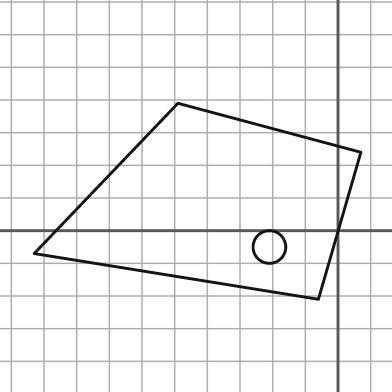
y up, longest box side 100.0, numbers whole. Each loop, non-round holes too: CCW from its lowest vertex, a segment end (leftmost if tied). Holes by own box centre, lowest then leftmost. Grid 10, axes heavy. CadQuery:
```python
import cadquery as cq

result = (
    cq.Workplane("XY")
    .moveTo(-6.0, -21.0)
    .lineTo(7.0, 24.0)
    .lineTo(-49.0, 39.0)
    .lineTo(-93.0, -7.0)
    .close()
    .moveTo(-21.0, -5.0)
    .circle(5.0)
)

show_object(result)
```